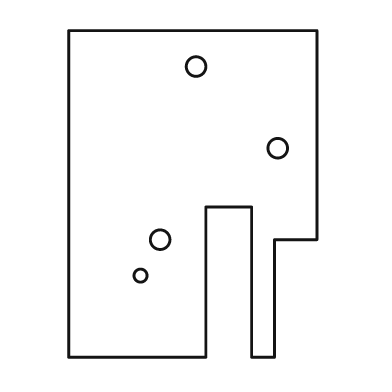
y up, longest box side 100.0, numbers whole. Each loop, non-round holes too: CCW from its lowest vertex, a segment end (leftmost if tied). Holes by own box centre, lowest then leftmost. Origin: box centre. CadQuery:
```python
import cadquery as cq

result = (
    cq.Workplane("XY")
    .moveTo(-38.0, -50.0)
    .lineTo(4.0, -50.0)
    .lineTo(4.0, -4.0)
    .lineTo(18.0, -4.0)
    .lineTo(18.0, -50.0)
    .lineTo(25.0, -50.0)
    .lineTo(25.0, -14.0)
    .lineTo(38.0, -14.0)
    .lineTo(38.0, 50.0)
    .lineTo(-38.0, 50.0)
    .close()
    .moveTo(-16.0, -25.0)
    .circle(2.0)
    .moveTo(-10.0, -14.0)
    .circle(3.0)
    .moveTo(26.0, 14.0)
    .circle(3.0)
    .moveTo(1.0, 39.0)
    .circle(3.0)
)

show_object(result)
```